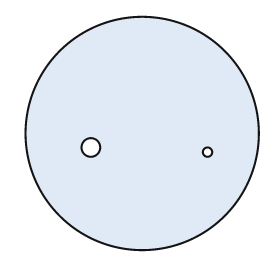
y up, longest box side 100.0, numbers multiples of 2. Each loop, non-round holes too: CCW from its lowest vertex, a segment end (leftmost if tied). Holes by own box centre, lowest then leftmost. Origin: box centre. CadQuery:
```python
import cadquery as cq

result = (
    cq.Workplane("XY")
    .moveTo(0.0, 0.0)
    .circle(50.0)
    .moveTo(28.0, -8.0)
    .circle(2.0)
    .moveTo(-22.0, -6.0)
    .circle(4.0)
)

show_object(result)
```